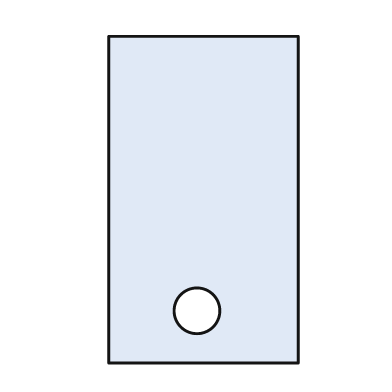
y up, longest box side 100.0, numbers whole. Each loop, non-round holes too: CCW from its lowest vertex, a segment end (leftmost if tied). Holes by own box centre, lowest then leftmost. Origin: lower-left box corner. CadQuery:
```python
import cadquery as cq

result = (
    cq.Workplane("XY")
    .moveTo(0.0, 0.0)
    .lineTo(58.0, 0.0)
    .lineTo(58.0, 100.0)
    .lineTo(0.0, 100.0)
    .close()
    .moveTo(27.0, 16.0)
    .circle(7.0)
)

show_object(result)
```